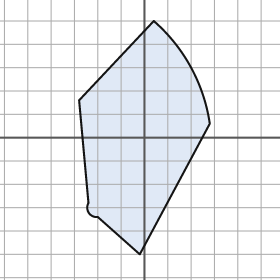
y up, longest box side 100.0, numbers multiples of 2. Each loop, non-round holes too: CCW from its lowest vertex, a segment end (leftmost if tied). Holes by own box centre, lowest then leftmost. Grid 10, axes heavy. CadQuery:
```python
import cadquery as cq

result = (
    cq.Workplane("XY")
    .moveTo(-2.0, -50.0)
    .lineTo(28.0, 6.0)
    .threePointArc((20.0, 30.0), (4.0, 50.0))
    .lineTo(-28.0, 16.0)
    .lineTo(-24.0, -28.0)
    .threePointArc((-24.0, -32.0), (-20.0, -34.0))
    .close()
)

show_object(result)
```